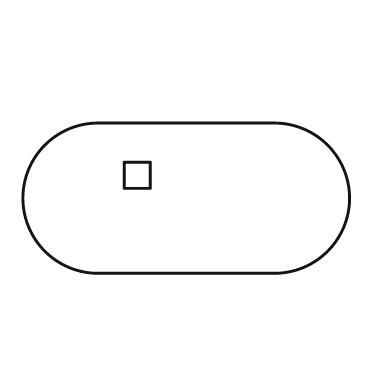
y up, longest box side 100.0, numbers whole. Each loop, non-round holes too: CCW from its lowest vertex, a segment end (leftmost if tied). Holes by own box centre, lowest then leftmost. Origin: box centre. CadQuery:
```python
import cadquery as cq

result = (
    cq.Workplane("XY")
    .moveTo(-27.0, -23.0)
    .lineTo(27.0, -23.0)
    .threePointArc((50.0, 0.0), (27.0, 23.0))
    .lineTo(-27.0, 23.0)
    .threePointArc((-50.0, 0.0), (-27.0, -23.0))
    .close()
    .moveTo(-19.0, 3.0)
    .lineTo(-11.0, 3.0)
    .lineTo(-11.0, 11.0)
    .lineTo(-19.0, 11.0)
    .close()
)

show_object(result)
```